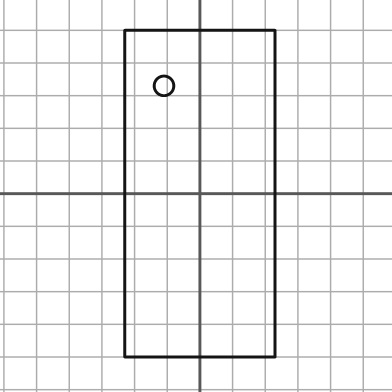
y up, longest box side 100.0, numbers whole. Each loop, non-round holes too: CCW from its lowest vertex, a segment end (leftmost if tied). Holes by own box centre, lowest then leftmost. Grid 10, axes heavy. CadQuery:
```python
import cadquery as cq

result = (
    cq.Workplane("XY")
    .moveTo(-23.0, -50.0)
    .lineTo(23.0, -50.0)
    .lineTo(23.0, 50.0)
    .lineTo(-23.0, 50.0)
    .close()
    .moveTo(-11.0, 33.0)
    .circle(3.0)
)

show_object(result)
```